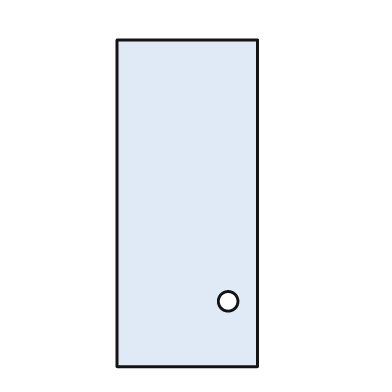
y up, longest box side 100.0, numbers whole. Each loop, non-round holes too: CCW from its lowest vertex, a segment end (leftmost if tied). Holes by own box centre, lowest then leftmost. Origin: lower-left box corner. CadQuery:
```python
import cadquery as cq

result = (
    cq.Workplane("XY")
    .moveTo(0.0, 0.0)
    .lineTo(43.0, 0.0)
    .lineTo(43.0, 100.0)
    .lineTo(0.0, 100.0)
    .close()
    .moveTo(34.0, 20.0)
    .circle(3.0)
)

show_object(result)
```